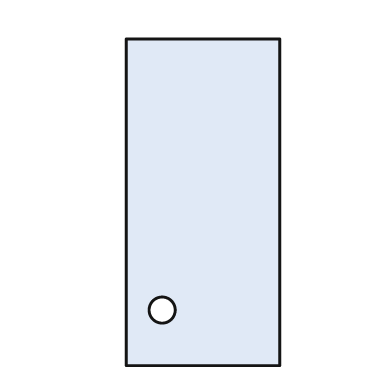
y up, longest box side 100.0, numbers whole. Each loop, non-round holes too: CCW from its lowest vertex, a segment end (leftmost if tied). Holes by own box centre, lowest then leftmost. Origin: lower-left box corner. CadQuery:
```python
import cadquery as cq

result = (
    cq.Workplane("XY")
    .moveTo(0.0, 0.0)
    .lineTo(47.0, 0.0)
    .lineTo(47.0, 100.0)
    .lineTo(0.0, 100.0)
    .close()
    .moveTo(11.0, 17.0)
    .circle(4.0)
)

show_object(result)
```